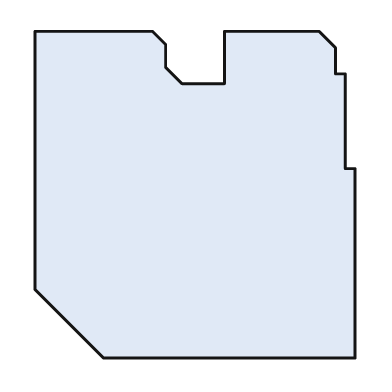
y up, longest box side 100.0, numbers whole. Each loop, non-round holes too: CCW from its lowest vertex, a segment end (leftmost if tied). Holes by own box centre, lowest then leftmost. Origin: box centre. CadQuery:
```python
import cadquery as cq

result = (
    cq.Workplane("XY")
    .moveTo(-28.0, -50.0)
    .lineTo(49.0, -50.0)
    .lineTo(49.0, 8.0)
    .lineTo(46.0, 8.0)
    .lineTo(46.0, 37.0)
    .lineTo(43.0, 37.0)
    .lineTo(43.0, 45.0)
    .lineTo(38.0, 50.0)
    .lineTo(9.0, 50.0)
    .lineTo(9.0, 34.0)
    .lineTo(-4.0, 34.0)
    .lineTo(-9.0, 39.0)
    .lineTo(-9.0, 46.0)
    .lineTo(-13.0, 50.0)
    .lineTo(-49.0, 50.0)
    .lineTo(-49.0, -29.0)
    .close()
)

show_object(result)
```